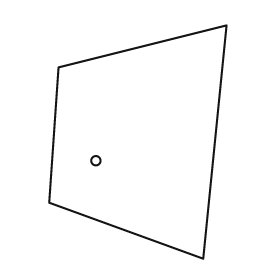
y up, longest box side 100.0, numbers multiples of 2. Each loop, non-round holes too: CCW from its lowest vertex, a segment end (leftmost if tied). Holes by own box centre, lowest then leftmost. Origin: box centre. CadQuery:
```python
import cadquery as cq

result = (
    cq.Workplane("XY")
    .moveTo(28.0, -50.0)
    .lineTo(38.0, 50.0)
    .lineTo(-34.0, 32.0)
    .lineTo(-38.0, -26.0)
    .close()
    .moveTo(-18.0, -8.0)
    .circle(2.0)
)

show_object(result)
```